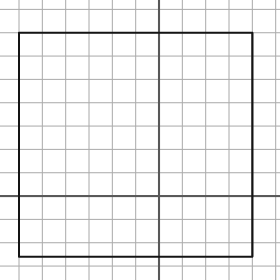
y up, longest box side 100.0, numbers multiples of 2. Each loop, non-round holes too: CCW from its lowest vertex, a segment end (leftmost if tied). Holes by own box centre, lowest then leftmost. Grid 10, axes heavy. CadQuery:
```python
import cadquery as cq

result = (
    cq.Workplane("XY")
    .moveTo(-60.0, -26.0)
    .lineTo(40.0, -26.0)
    .lineTo(40.0, 70.0)
    .lineTo(-60.0, 70.0)
    .close()
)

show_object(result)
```